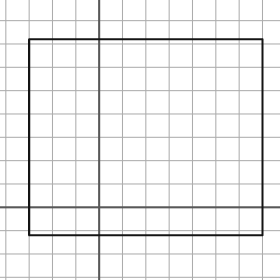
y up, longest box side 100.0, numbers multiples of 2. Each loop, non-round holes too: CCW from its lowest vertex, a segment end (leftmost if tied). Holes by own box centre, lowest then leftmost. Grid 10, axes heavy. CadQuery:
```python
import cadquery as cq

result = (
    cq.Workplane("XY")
    .moveTo(-30.0, -12.0)
    .lineTo(70.0, -12.0)
    .lineTo(70.0, 72.0)
    .lineTo(-30.0, 72.0)
    .close()
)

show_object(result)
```